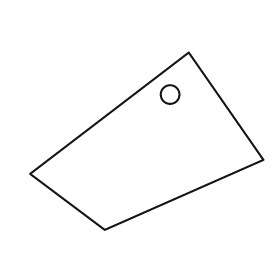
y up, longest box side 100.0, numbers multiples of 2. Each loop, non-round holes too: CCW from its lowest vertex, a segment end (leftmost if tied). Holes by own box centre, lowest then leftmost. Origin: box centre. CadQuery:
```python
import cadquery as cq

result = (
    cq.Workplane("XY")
    .moveTo(-18.0, -38.0)
    .lineTo(50.0, -8.0)
    .lineTo(18.0, 38.0)
    .lineTo(-50.0, -14.0)
    .close()
    .moveTo(10.0, 20.0)
    .circle(4.0)
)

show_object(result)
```